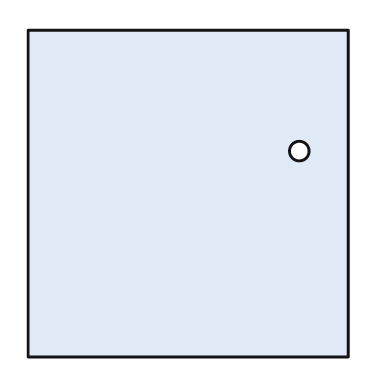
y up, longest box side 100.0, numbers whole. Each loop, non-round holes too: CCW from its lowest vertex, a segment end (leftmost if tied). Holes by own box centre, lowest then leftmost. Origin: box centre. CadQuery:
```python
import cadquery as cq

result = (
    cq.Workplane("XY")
    .moveTo(-49.0, -50.0)
    .lineTo(49.0, -50.0)
    .lineTo(49.0, 50.0)
    .lineTo(-49.0, 50.0)
    .close()
    .moveTo(34.0, 13.0)
    .circle(3.0)
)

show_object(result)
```